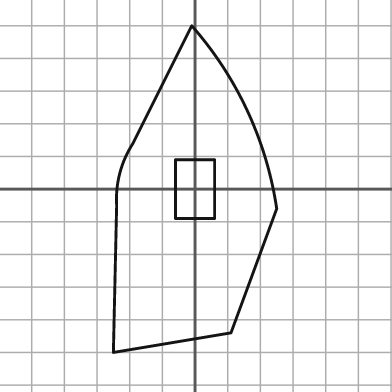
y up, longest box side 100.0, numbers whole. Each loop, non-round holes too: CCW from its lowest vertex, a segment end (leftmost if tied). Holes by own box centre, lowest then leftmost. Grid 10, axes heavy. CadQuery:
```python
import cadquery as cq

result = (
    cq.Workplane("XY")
    .moveTo(-25.0, -50.0)
    .lineTo(11.0, -44.0)
    .lineTo(25.0, -6.0)
    .threePointArc((16.0, 24.0), (-1.0, 50.0))
    .lineTo(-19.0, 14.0)
    .threePointArc((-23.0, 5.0), (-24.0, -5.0))
    .close()
    .moveTo(-6.0, -9.0)
    .lineTo(6.0, -9.0)
    .lineTo(6.0, 9.0)
    .lineTo(-6.0, 9.0)
    .close()
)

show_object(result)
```